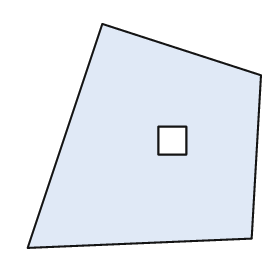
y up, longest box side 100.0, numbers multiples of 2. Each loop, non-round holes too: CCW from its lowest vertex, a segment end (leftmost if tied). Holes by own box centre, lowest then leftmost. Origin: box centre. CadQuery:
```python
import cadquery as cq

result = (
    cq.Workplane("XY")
    .moveTo(-50.0, -48.0)
    .lineTo(46.0, -44.0)
    .lineTo(50.0, 26.0)
    .lineTo(-18.0, 48.0)
    .close()
    .moveTo(6.0, -8.0)
    .lineTo(18.0, -8.0)
    .lineTo(18.0, 4.0)
    .lineTo(6.0, 4.0)
    .close()
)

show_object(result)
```